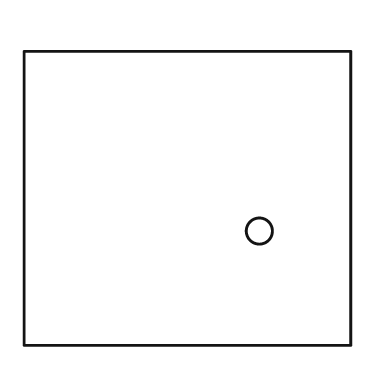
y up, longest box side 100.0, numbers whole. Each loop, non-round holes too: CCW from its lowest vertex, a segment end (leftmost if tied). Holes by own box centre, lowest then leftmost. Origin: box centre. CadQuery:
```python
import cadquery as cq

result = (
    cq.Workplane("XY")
    .moveTo(-50.0, -45.0)
    .lineTo(50.0, -45.0)
    .lineTo(50.0, 45.0)
    .lineTo(-50.0, 45.0)
    .close()
    .moveTo(22.0, -10.0)
    .circle(4.0)
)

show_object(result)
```